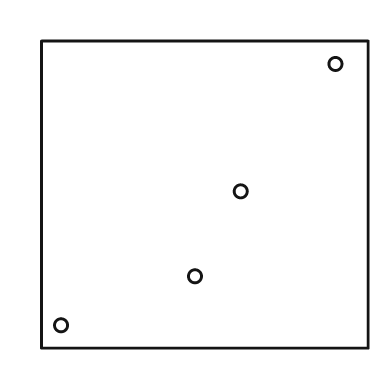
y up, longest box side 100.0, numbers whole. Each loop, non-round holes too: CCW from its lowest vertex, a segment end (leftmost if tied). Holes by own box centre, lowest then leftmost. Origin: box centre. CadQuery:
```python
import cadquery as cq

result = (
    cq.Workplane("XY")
    .moveTo(-50.0, -47.0)
    .lineTo(50.0, -47.0)
    .lineTo(50.0, 47.0)
    .lineTo(-50.0, 47.0)
    .close()
    .moveTo(-44.0, -40.0)
    .circle(2.0)
    .moveTo(-3.0, -25.0)
    .circle(2.0)
    .moveTo(11.0, 1.0)
    .circle(2.0)
    .moveTo(40.0, 40.0)
    .circle(2.0)
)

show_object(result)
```